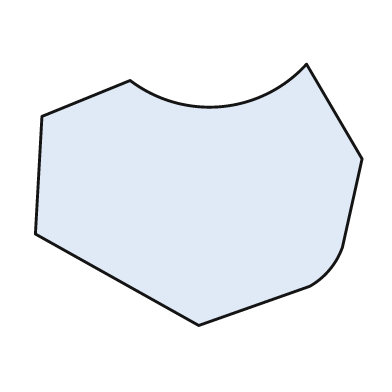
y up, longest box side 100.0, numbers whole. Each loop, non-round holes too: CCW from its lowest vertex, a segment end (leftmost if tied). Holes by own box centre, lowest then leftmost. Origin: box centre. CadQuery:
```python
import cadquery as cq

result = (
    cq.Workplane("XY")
    .moveTo(0.0, -40.0)
    .lineTo(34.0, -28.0)
    .threePointArc((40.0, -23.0), (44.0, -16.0))
    .lineTo(50.0, 11.0)
    .lineTo(33.0, 40.0)
    .threePointArc((7.0, 27.0), (-21.0, 35.0))
    .lineTo(-48.0, 24.0)
    .lineTo(-50.0, -12.0)
    .close()
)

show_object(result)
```